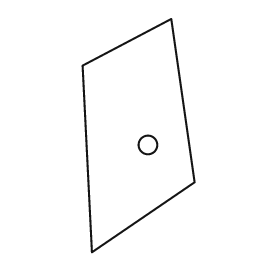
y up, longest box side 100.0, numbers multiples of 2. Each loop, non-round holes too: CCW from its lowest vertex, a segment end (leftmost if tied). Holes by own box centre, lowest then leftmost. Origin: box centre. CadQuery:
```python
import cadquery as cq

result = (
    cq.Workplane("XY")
    .moveTo(-20.0, -50.0)
    .lineTo(24.0, -20.0)
    .lineTo(14.0, 50.0)
    .lineTo(-24.0, 30.0)
    .close()
    .moveTo(4.0, -4.0)
    .circle(4.0)
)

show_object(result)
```